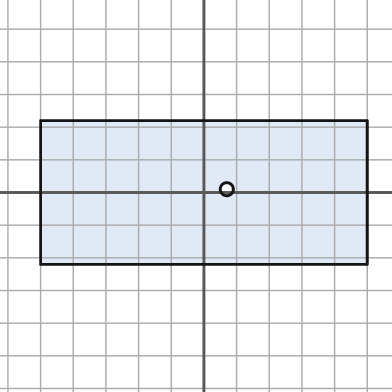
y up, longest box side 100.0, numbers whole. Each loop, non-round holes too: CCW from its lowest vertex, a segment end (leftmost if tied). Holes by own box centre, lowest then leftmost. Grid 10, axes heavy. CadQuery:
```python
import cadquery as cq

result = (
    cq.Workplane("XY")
    .moveTo(-50.0, -22.0)
    .lineTo(50.0, -22.0)
    .lineTo(50.0, 22.0)
    .lineTo(-50.0, 22.0)
    .close()
    .moveTo(7.0, 1.0)
    .circle(2.0)
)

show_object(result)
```